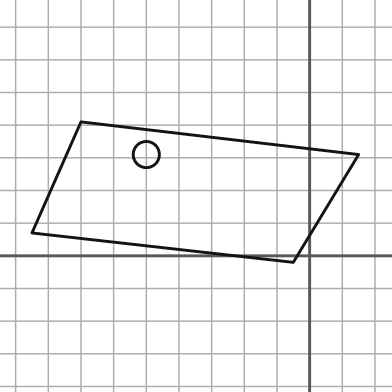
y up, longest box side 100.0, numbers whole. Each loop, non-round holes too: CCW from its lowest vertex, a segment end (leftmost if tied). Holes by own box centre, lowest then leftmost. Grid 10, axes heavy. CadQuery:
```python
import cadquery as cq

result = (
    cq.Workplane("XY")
    .moveTo(-5.0, -2.0)
    .lineTo(15.0, 31.0)
    .lineTo(-70.0, 41.0)
    .lineTo(-85.0, 7.0)
    .close()
    .moveTo(-50.0, 31.0)
    .circle(4.0)
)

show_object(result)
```